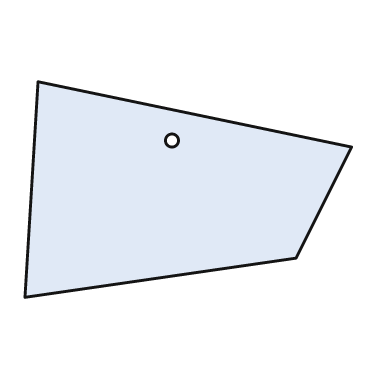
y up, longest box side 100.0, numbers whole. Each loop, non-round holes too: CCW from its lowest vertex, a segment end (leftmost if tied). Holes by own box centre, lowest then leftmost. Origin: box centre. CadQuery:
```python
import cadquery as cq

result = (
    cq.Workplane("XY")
    .moveTo(-50.0, -33.0)
    .lineTo(33.0, -21.0)
    .lineTo(50.0, 13.0)
    .lineTo(-46.0, 33.0)
    .close()
    .moveTo(-5.0, 15.0)
    .circle(2.0)
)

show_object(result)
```